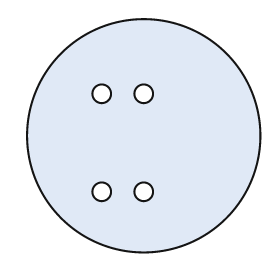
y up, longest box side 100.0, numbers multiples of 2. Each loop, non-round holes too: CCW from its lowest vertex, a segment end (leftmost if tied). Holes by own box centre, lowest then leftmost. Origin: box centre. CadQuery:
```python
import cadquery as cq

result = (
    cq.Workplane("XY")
    .moveTo(0.0, 0.0)
    .circle(50.0)
    .moveTo(-18.0, -24.0)
    .circle(4.0)
    .moveTo(0.0, -24.0)
    .circle(4.0)
    .moveTo(-18.0, 18.0)
    .circle(4.0)
    .moveTo(0.0, 18.0)
    .circle(4.0)
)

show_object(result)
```